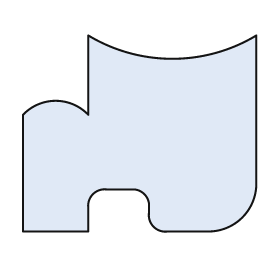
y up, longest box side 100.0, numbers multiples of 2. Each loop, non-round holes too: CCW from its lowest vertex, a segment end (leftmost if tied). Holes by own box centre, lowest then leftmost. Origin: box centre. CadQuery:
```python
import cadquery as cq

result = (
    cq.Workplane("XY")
    .moveTo(-50.0, -42.0)
    .lineTo(-22.0, -42.0)
    .lineTo(-22.0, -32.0)
    .threePointArc((-20.0, -26.0), (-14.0, -24.0))
    .lineTo(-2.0, -24.0)
    .threePointArc((2.0, -26.0), (4.0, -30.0))
    .lineTo(4.0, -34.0)
    .threePointArc((6.0, -40.0), (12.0, -42.0))
    .lineTo(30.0, -42.0)
    .threePointArc((44.0, -36.0), (50.0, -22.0))
    .lineTo(50.0, 42.0)
    .threePointArc((14.0, 32.0), (-22.0, 42.0))
    .lineTo(-22.0, 8.0)
    .threePointArc((-36.0, 14.0), (-50.0, 8.0))
    .close()
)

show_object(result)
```